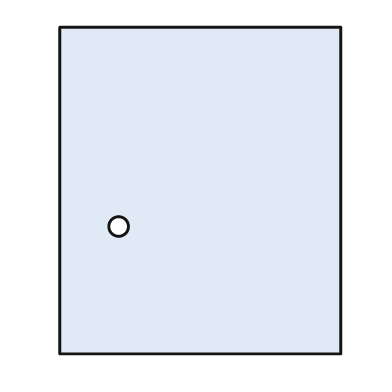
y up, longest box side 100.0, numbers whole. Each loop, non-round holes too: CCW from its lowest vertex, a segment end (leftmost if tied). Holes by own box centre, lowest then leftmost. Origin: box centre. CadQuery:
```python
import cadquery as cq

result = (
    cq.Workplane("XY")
    .moveTo(-43.0, -50.0)
    .lineTo(43.0, -50.0)
    .lineTo(43.0, 50.0)
    .lineTo(-43.0, 50.0)
    .close()
    .moveTo(-25.0, -11.0)
    .circle(3.0)
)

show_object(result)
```